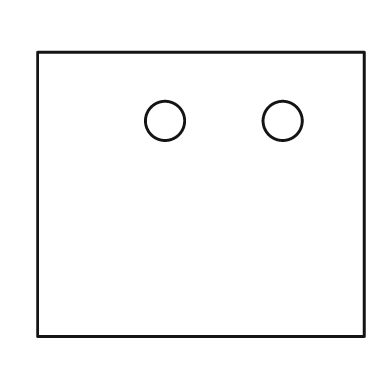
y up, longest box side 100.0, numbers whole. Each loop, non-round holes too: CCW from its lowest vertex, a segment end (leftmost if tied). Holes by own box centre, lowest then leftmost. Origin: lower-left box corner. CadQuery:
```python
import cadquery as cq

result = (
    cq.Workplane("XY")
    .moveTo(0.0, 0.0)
    .lineTo(100.0, 0.0)
    .lineTo(100.0, 87.0)
    .lineTo(0.0, 87.0)
    .close()
    .moveTo(39.0, 66.0)
    .circle(6.0)
    .moveTo(75.0, 66.0)
    .circle(6.0)
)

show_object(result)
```